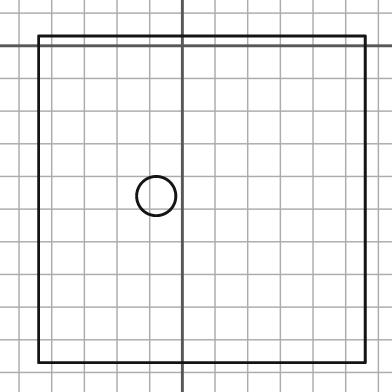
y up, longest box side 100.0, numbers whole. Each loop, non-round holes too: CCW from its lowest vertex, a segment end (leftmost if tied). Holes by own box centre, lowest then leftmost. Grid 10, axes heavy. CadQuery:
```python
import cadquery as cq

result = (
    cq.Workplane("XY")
    .moveTo(-44.0, -97.0)
    .lineTo(56.0, -97.0)
    .lineTo(56.0, 3.0)
    .lineTo(-44.0, 3.0)
    .close()
    .moveTo(-8.0, -46.0)
    .circle(6.0)
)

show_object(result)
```